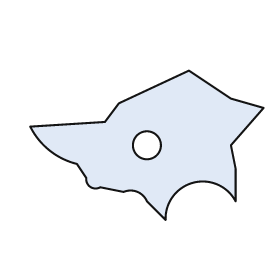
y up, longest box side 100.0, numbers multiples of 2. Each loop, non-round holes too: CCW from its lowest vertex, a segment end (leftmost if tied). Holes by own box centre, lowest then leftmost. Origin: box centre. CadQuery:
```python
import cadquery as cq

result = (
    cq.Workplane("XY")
    .moveTo(8.0, -32.0)
    .threePointArc((20.0, -16.0), (38.0, -24.0))
    .lineTo(38.0, -10.0)
    .lineTo(36.0, 0.0)
    .lineTo(50.0, 16.0)
    .lineTo(36.0, 20.0)
    .lineTo(18.0, 32.0)
    .lineTo(-12.0, 18.0)
    .lineTo(-18.0, 10.0)
    .lineTo(-50.0, 8.0)
    .threePointArc((-42.0, -2.0), (-30.0, -8.0))
    .lineTo(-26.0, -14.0)
    .threePointArc((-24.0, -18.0), (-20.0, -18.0))
    .lineTo(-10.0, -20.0)
    .threePointArc((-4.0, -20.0), (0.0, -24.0))
    .close()
    .moveTo(0.0, 0.0)
    .circle(6.0)
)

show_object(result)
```